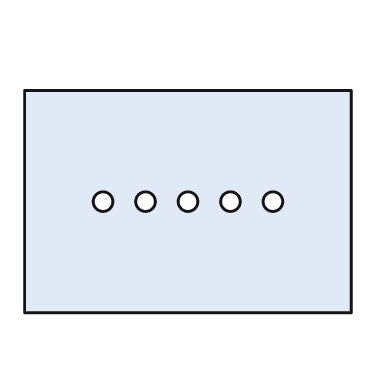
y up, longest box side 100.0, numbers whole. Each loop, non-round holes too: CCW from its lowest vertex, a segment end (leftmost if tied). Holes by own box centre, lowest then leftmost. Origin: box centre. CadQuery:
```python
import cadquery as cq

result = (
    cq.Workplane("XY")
    .moveTo(-50.0, -34.0)
    .lineTo(50.0, -34.0)
    .lineTo(50.0, 34.0)
    .lineTo(-50.0, 34.0)
    .close()
    .moveTo(-26.0, 0.0)
    .circle(3.0)
    .moveTo(-13.0, 0.0)
    .circle(3.0)
    .moveTo(0.0, 0.0)
    .circle(3.0)
    .moveTo(13.0, 0.0)
    .circle(3.0)
    .moveTo(26.0, 0.0)
    .circle(3.0)
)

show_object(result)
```